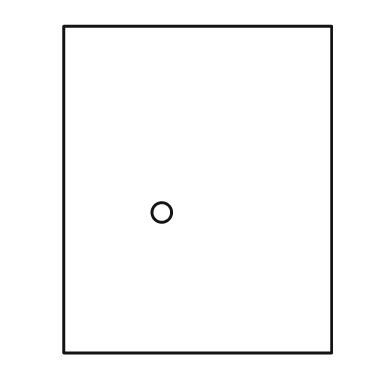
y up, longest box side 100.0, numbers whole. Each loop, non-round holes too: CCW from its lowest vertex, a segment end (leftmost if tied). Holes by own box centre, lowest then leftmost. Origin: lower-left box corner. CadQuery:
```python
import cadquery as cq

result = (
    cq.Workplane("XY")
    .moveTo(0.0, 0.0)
    .lineTo(82.0, 0.0)
    .lineTo(82.0, 100.0)
    .lineTo(0.0, 100.0)
    .close()
    .moveTo(30.0, 43.0)
    .circle(3.0)
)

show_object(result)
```